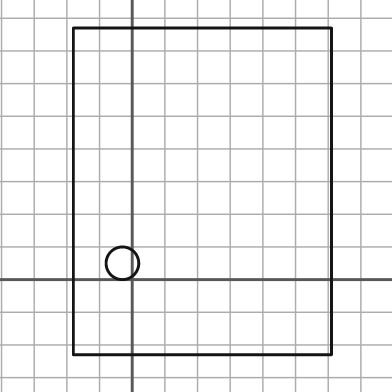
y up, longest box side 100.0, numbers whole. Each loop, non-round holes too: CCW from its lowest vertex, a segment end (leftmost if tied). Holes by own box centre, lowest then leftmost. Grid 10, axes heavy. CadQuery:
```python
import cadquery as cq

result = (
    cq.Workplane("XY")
    .moveTo(-18.0, -23.0)
    .lineTo(61.0, -23.0)
    .lineTo(61.0, 77.0)
    .lineTo(-18.0, 77.0)
    .close()
    .moveTo(-3.0, 5.0)
    .circle(5.0)
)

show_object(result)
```